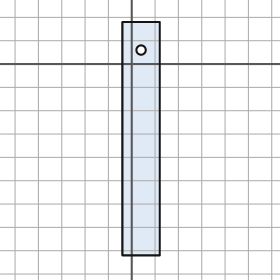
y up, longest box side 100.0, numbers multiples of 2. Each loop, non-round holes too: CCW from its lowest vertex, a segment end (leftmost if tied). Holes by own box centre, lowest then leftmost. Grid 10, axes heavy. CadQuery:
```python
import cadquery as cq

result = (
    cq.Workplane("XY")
    .moveTo(-4.0, -82.0)
    .lineTo(12.0, -82.0)
    .lineTo(12.0, 18.0)
    .lineTo(-4.0, 18.0)
    .close()
    .moveTo(4.0, 6.0)
    .circle(2.0)
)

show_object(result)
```